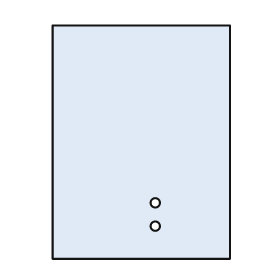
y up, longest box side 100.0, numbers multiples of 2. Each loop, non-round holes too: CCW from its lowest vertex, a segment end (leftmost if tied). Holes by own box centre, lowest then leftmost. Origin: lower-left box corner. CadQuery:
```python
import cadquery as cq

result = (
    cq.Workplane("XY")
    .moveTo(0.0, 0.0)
    .lineTo(76.0, 0.0)
    .lineTo(76.0, 100.0)
    .lineTo(0.0, 100.0)
    .close()
    .moveTo(44.0, 14.0)
    .circle(2.0)
    .moveTo(44.0, 24.0)
    .circle(2.0)
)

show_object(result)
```